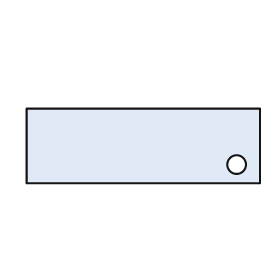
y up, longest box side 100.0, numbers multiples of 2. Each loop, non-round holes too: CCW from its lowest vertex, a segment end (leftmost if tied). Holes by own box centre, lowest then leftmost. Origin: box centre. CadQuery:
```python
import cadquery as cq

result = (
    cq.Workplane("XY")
    .moveTo(-50.0, -16.0)
    .lineTo(50.0, -16.0)
    .lineTo(50.0, 16.0)
    .lineTo(-50.0, 16.0)
    .close()
    .moveTo(40.0, -8.0)
    .circle(4.0)
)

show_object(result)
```